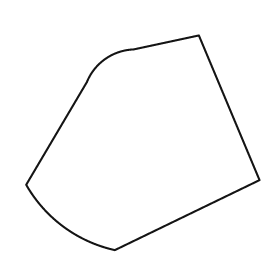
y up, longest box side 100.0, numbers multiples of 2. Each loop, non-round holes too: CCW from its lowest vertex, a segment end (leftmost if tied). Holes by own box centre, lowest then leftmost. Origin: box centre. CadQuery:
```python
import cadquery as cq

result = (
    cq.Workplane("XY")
    .moveTo(-12.0, -46.0)
    .lineTo(50.0, -16.0)
    .lineTo(24.0, 46.0)
    .lineTo(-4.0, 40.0)
    .threePointArc((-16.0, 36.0), (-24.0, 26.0))
    .lineTo(-50.0, -18.0)
    .threePointArc((-34.0, -36.0), (-12.0, -46.0))
    .close()
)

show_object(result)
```